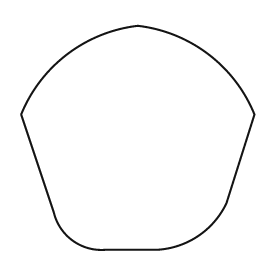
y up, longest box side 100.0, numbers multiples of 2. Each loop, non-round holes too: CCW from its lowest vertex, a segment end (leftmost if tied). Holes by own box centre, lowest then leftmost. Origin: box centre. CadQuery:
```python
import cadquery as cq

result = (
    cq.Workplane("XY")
    .moveTo(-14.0, -48.0)
    .lineTo(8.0, -48.0)
    .threePointArc((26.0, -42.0), (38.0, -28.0))
    .lineTo(50.0, 10.0)
    .threePointArc((30.0, 36.0), (0.0, 48.0))
    .threePointArc((-30.0, 36.0), (-50.0, 10.0))
    .lineTo(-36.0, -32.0)
    .threePointArc((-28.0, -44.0), (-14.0, -48.0))
    .close()
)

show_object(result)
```